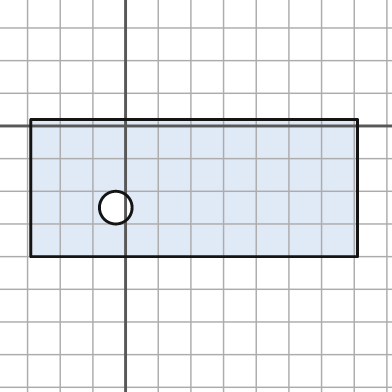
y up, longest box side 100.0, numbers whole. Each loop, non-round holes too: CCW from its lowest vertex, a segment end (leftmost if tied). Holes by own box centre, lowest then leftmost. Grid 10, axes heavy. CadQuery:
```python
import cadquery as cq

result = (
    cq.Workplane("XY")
    .moveTo(-29.0, -40.0)
    .lineTo(71.0, -40.0)
    .lineTo(71.0, 2.0)
    .lineTo(-29.0, 2.0)
    .close()
    .moveTo(-3.0, -25.0)
    .circle(5.0)
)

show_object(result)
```